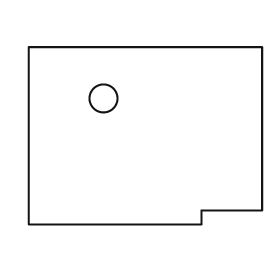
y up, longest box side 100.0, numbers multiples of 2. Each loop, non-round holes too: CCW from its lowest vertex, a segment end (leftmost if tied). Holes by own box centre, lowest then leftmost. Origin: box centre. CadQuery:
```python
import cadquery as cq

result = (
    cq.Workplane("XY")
    .moveTo(-50.0, -38.0)
    .lineTo(24.0, -38.0)
    .lineTo(24.0, -32.0)
    .lineTo(50.0, -32.0)
    .lineTo(50.0, 38.0)
    .lineTo(-50.0, 38.0)
    .close()
    .moveTo(-18.0, 16.0)
    .circle(6.0)
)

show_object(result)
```